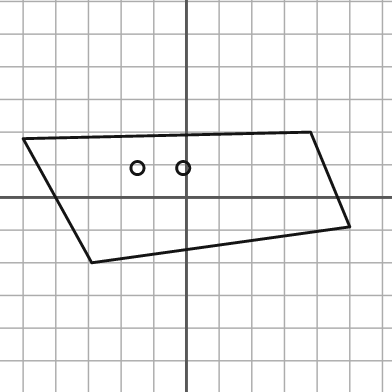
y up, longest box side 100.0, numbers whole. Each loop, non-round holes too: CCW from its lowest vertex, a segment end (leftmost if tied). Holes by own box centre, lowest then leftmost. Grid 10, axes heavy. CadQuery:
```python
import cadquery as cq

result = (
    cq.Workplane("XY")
    .moveTo(-29.0, -20.0)
    .lineTo(50.0, -9.0)
    .lineTo(38.0, 20.0)
    .lineTo(-50.0, 18.0)
    .close()
    .moveTo(-15.0, 9.0)
    .circle(2.0)
    .moveTo(-1.0, 9.0)
    .circle(2.0)
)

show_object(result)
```